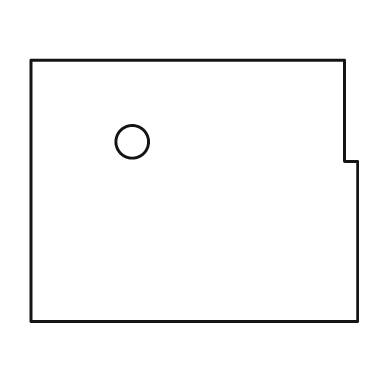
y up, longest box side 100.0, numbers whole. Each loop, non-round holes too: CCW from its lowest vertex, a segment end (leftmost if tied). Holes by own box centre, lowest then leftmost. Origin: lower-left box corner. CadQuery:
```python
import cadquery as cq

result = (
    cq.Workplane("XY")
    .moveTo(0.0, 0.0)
    .lineTo(100.0, 0.0)
    .lineTo(100.0, 49.0)
    .lineTo(96.0, 49.0)
    .lineTo(96.0, 80.0)
    .lineTo(0.0, 80.0)
    .close()
    .moveTo(31.0, 55.0)
    .circle(5.0)
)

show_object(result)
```